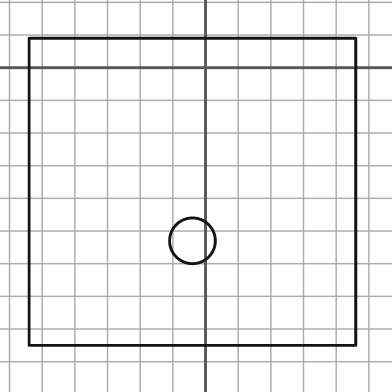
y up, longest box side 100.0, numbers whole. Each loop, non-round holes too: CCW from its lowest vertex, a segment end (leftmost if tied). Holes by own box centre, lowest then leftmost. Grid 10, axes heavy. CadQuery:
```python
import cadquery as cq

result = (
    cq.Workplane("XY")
    .moveTo(-54.0, -85.0)
    .lineTo(46.0, -85.0)
    .lineTo(46.0, 9.0)
    .lineTo(-54.0, 9.0)
    .close()
    .moveTo(-4.0, -53.0)
    .circle(7.0)
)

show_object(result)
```